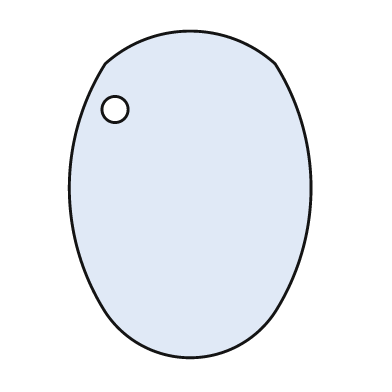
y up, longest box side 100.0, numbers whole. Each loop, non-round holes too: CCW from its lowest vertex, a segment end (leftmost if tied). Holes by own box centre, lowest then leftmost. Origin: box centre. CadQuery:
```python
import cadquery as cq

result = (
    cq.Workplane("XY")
    .moveTo(-26.0, -36.0)
    .threePointArc((0.0, -50.0), (26.0, -36.0))
    .threePointArc((37.0, 2.0), (26.0, 40.0))
    .threePointArc((0.0, 50.0), (-26.0, 40.0))
    .threePointArc((-37.0, 2.0), (-26.0, -36.0))
    .close()
    .moveTo(-23.0, 26.0)
    .circle(4.0)
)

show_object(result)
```